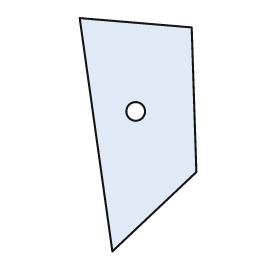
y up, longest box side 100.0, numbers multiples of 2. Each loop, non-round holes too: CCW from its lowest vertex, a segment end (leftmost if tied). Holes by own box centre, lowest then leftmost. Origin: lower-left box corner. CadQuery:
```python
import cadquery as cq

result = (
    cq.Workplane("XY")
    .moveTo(14.0, 0.0)
    .lineTo(50.0, 34.0)
    .lineTo(48.0, 96.0)
    .lineTo(0.0, 100.0)
    .close()
    .moveTo(24.0, 60.0)
    .circle(4.0)
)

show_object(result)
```